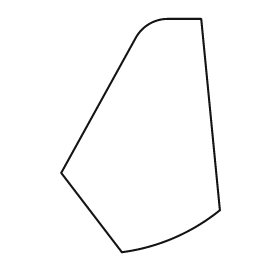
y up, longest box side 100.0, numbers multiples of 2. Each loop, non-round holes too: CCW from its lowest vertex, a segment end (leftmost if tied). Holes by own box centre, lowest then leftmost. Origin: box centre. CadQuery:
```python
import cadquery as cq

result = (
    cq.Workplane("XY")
    .moveTo(-8.0, -50.0)
    .threePointArc((14.0, -44.0), (34.0, -32.0))
    .lineTo(26.0, 50.0)
    .lineTo(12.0, 50.0)
    .threePointArc((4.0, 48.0), (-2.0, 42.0))
    .lineTo(-34.0, -16.0)
    .close()
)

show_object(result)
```